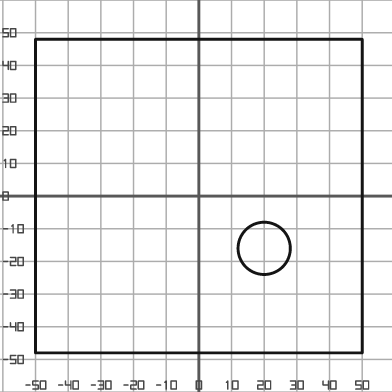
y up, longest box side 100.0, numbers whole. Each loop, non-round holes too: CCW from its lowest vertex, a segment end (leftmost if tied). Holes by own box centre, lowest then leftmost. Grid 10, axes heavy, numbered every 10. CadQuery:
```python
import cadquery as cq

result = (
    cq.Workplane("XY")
    .moveTo(-50.0, -48.0)
    .lineTo(50.0, -48.0)
    .lineTo(50.0, 48.0)
    .lineTo(-50.0, 48.0)
    .close()
    .moveTo(20.0, -16.0)
    .circle(8.0)
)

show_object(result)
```